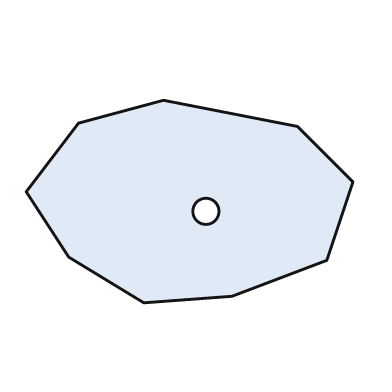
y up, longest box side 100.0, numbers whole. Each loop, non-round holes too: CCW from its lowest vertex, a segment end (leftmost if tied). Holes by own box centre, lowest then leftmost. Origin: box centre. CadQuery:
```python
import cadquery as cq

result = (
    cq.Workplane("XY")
    .moveTo(-14.0, -31.0)
    .lineTo(13.0, -29.0)
    .lineTo(42.0, -18.0)
    .lineTo(50.0, 6.0)
    .lineTo(33.0, 23.0)
    .lineTo(-8.0, 31.0)
    .lineTo(-34.0, 24.0)
    .lineTo(-50.0, 3.0)
    .lineTo(-37.0, -17.0)
    .close()
    .moveTo(5.0, -3.0)
    .circle(4.0)
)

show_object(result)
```